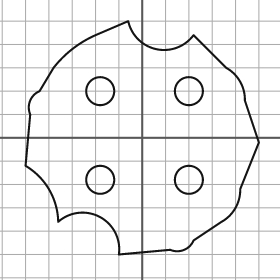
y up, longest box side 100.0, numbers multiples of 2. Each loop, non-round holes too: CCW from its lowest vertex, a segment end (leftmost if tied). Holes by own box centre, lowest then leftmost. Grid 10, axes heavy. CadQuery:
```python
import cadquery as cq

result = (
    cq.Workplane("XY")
    .moveTo(-10.0, -50.0)
    .lineTo(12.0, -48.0)
    .threePointArc((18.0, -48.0), (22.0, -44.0))
    .lineTo(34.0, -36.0)
    .threePointArc((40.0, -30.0), (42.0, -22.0))
    .lineTo(50.0, -2.0)
    .lineTo(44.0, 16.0)
    .threePointArc((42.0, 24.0), (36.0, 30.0))
    .lineTo(22.0, 44.0)
    .threePointArc((6.0, 38.0), (-6.0, 50.0))
    .lineTo(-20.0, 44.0)
    .threePointArc((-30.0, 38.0), (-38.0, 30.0))
    .lineTo(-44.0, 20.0)
    .threePointArc((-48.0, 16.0), (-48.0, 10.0))
    .lineTo(-50.0, -12.0)
    .threePointArc((-40.0, -22.0), (-36.0, -36.0))
    .threePointArc((-18.0, -34.0), (-10.0, -50.0))
    .close()
    .moveTo(-18.0, -18.0)
    .circle(6.0)
    .moveTo(20.0, -18.0)
    .circle(6.0)
    .moveTo(-18.0, 20.0)
    .circle(6.0)
    .moveTo(20.0, 20.0)
    .circle(6.0)
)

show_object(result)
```